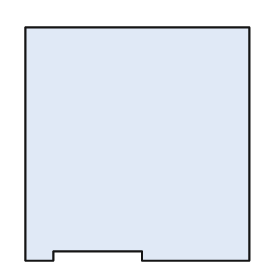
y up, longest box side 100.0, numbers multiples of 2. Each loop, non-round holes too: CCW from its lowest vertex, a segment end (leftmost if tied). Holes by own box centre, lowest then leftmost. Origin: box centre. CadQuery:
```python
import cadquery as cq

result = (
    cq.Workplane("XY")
    .moveTo(-48.0, -50.0)
    .lineTo(-36.0, -50.0)
    .lineTo(-36.0, -46.0)
    .lineTo(2.0, -46.0)
    .lineTo(2.0, -50.0)
    .lineTo(48.0, -50.0)
    .lineTo(48.0, 50.0)
    .lineTo(-48.0, 50.0)
    .close()
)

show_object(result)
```